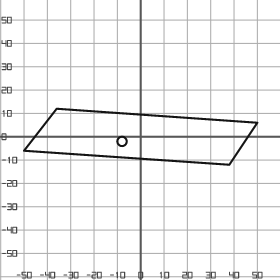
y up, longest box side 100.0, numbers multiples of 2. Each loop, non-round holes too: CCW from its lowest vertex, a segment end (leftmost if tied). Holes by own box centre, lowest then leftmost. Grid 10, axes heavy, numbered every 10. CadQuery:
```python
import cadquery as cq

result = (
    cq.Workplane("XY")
    .moveTo(38.0, -12.0)
    .lineTo(50.0, 6.0)
    .lineTo(-36.0, 12.0)
    .lineTo(-50.0, -6.0)
    .close()
    .moveTo(-8.0, -2.0)
    .circle(2.0)
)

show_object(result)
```